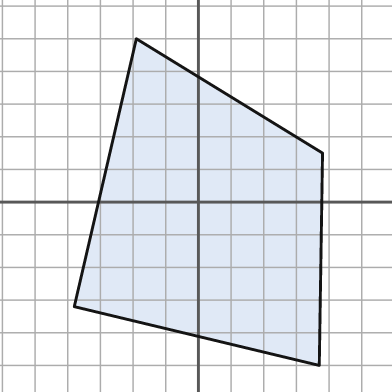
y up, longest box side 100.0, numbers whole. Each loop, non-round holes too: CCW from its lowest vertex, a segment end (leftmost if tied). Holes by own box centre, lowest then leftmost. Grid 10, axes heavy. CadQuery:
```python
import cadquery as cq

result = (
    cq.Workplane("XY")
    .moveTo(37.0, -50.0)
    .lineTo(38.0, 15.0)
    .lineTo(-19.0, 50.0)
    .lineTo(-38.0, -32.0)
    .close()
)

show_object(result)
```